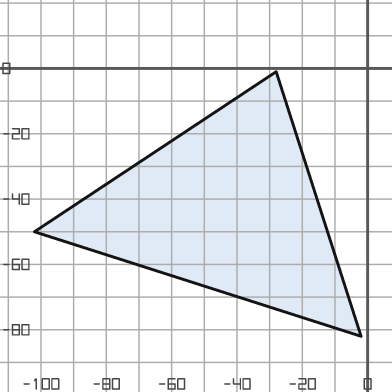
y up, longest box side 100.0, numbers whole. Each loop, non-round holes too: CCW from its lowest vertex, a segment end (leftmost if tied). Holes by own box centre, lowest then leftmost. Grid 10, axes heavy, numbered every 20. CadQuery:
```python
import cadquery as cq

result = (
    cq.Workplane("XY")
    .moveTo(-2.0, -82.0)
    .lineTo(-28.0, -1.0)
    .lineTo(-102.0, -50.0)
    .close()
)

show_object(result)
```